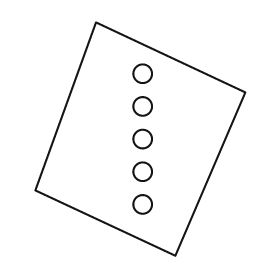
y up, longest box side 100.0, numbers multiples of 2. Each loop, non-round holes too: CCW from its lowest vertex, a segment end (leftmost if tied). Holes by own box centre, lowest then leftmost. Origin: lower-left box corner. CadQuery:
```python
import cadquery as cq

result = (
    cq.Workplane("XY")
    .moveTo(60.0, 0.0)
    .lineTo(90.0, 70.0)
    .lineTo(26.0, 100.0)
    .lineTo(0.0, 28.0)
    .close()
    .moveTo(46.0, 22.0)
    .circle(4.0)
    .moveTo(46.0, 36.0)
    .circle(4.0)
    .moveTo(46.0, 50.0)
    .circle(4.0)
    .moveTo(46.0, 64.0)
    .circle(4.0)
    .moveTo(46.0, 78.0)
    .circle(4.0)
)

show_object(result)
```